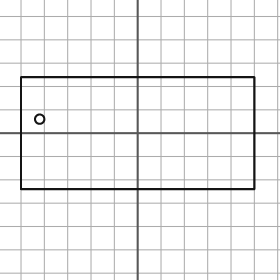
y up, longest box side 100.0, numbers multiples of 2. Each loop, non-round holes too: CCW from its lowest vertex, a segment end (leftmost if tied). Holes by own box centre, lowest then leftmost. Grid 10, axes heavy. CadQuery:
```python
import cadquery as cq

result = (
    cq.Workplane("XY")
    .moveTo(-50.0, -24.0)
    .lineTo(50.0, -24.0)
    .lineTo(50.0, 24.0)
    .lineTo(-50.0, 24.0)
    .close()
    .moveTo(-42.0, 6.0)
    .circle(2.0)
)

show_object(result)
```